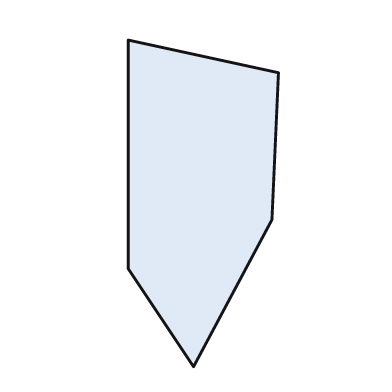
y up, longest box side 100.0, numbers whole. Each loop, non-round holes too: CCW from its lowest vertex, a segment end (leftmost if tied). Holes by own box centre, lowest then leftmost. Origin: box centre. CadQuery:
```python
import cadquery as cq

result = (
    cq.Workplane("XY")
    .moveTo(-3.0, -50.0)
    .lineTo(21.0, -5.0)
    .lineTo(23.0, 40.0)
    .lineTo(-23.0, 50.0)
    .lineTo(-23.0, -20.0)
    .close()
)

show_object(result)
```